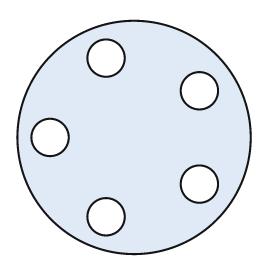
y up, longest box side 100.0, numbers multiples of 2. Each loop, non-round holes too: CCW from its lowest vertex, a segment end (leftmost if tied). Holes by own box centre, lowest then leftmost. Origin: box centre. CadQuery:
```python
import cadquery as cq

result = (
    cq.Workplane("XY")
    .moveTo(0.0, 0.0)
    .circle(50.0)
    .moveTo(-12.0, -34.0)
    .circle(8.0)
    .moveTo(28.0, -20.0)
    .circle(8.0)
    .moveTo(-36.0, 0.0)
    .circle(8.0)
    .moveTo(28.0, 20.0)
    .circle(8.0)
    .moveTo(-12.0, 34.0)
    .circle(8.0)
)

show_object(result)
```